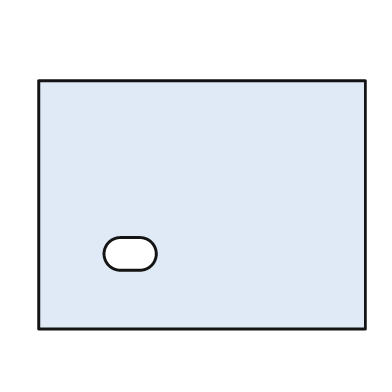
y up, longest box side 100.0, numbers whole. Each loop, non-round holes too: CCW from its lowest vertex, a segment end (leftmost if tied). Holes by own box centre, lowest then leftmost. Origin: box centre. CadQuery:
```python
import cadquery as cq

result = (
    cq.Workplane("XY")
    .moveTo(-50.0, -38.0)
    .lineTo(50.0, -38.0)
    .lineTo(50.0, 38.0)
    .lineTo(-50.0, 38.0)
    .close()
    .moveTo(-25.0, -20.0)
    .lineTo(-19.0, -20.0)
    .threePointArc((-14.0, -15.0), (-19.0, -10.0))
    .lineTo(-25.0, -10.0)
    .threePointArc((-30.0, -15.0), (-25.0, -20.0))
    .close()
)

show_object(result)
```